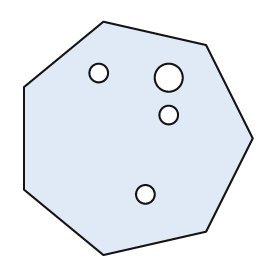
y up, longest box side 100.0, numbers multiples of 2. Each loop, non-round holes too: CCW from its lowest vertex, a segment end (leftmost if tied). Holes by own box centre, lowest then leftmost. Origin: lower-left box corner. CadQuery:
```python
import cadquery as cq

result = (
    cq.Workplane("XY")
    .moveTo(34.0, 0.0)
    .lineTo(78.0, 10.0)
    .lineTo(98.0, 50.0)
    .lineTo(78.0, 90.0)
    .lineTo(34.0, 100.0)
    .lineTo(0.0, 72.0)
    .lineTo(0.0, 28.0)
    .close()
    .moveTo(52.0, 26.0)
    .circle(4.0)
    .moveTo(62.0, 60.0)
    .circle(4.0)
    .moveTo(62.0, 76.0)
    .circle(6.0)
    .moveTo(32.0, 78.0)
    .circle(4.0)
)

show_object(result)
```